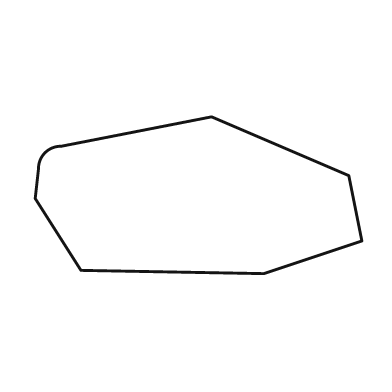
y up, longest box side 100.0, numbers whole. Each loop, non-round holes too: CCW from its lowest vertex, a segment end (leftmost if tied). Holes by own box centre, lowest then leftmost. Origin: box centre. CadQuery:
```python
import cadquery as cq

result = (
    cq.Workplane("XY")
    .moveTo(20.0, -24.0)
    .lineTo(50.0, -14.0)
    .lineTo(46.0, 6.0)
    .lineTo(4.0, 24.0)
    .lineTo(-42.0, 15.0)
    .threePointArc((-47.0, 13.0), (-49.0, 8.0))
    .lineTo(-50.0, -1.0)
    .lineTo(-36.0, -23.0)
    .close()
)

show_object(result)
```